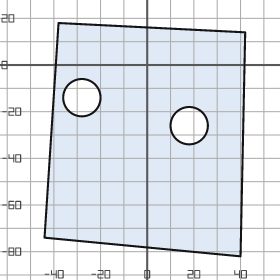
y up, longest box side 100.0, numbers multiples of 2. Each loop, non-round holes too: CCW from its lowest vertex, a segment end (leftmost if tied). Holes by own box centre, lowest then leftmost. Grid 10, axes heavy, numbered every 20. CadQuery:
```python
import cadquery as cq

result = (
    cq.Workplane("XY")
    .moveTo(40.0, -82.0)
    .lineTo(42.0, 14.0)
    .lineTo(-38.0, 18.0)
    .lineTo(-44.0, -74.0)
    .close()
    .moveTo(18.0, -26.0)
    .circle(8.0)
    .moveTo(-28.0, -14.0)
    .circle(8.0)
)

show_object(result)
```